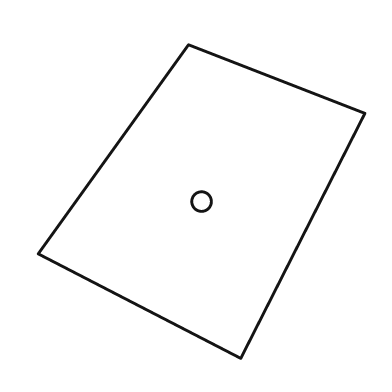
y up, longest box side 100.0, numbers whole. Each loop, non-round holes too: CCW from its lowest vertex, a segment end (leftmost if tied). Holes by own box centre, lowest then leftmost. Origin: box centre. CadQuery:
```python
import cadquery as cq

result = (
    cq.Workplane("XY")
    .moveTo(12.0, -48.0)
    .lineTo(50.0, 27.0)
    .lineTo(-4.0, 48.0)
    .lineTo(-50.0, -16.0)
    .close()
    .moveTo(0.0, 0.0)
    .circle(3.0)
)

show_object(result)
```